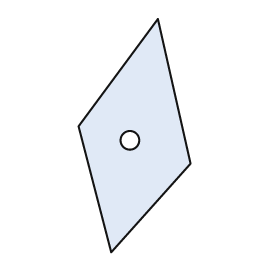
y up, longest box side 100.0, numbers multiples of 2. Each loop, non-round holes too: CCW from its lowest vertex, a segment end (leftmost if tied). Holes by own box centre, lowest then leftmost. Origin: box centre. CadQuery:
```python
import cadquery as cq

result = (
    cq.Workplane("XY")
    .moveTo(-10.0, -50.0)
    .lineTo(24.0, -12.0)
    .lineTo(10.0, 50.0)
    .lineTo(-24.0, 4.0)
    .close()
    .moveTo(-2.0, -2.0)
    .circle(4.0)
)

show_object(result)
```